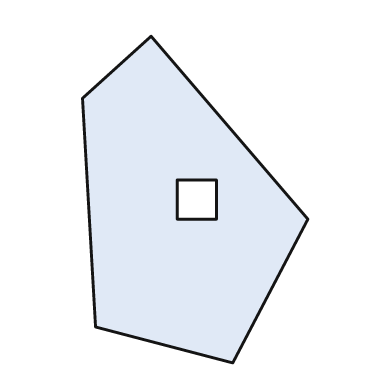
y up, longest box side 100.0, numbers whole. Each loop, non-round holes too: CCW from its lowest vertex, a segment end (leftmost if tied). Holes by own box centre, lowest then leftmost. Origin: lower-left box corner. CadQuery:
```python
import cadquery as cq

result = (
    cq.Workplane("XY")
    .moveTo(46.0, 0.0)
    .lineTo(69.0, 44.0)
    .lineTo(21.0, 100.0)
    .lineTo(0.0, 81.0)
    .lineTo(4.0, 11.0)
    .close()
    .moveTo(29.0, 44.0)
    .lineTo(41.0, 44.0)
    .lineTo(41.0, 56.0)
    .lineTo(29.0, 56.0)
    .close()
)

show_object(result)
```